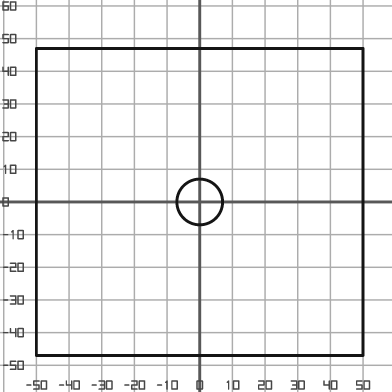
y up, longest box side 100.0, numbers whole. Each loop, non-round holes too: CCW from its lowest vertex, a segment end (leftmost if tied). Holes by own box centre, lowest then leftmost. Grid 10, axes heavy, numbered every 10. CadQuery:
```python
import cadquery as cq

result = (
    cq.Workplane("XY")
    .moveTo(-50.0, -47.0)
    .lineTo(50.0, -47.0)
    .lineTo(50.0, 47.0)
    .lineTo(-50.0, 47.0)
    .close()
    .moveTo(0.0, 0.0)
    .circle(7.0)
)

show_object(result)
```